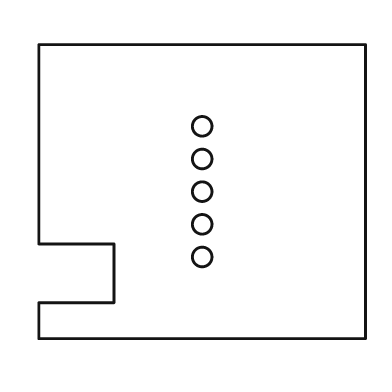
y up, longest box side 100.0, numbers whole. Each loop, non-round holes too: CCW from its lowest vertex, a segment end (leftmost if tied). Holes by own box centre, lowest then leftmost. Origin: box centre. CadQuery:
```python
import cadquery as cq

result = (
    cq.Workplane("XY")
    .moveTo(-50.0, -45.0)
    .lineTo(50.0, -45.0)
    .lineTo(50.0, 45.0)
    .lineTo(-50.0, 45.0)
    .lineTo(-50.0, -16.0)
    .lineTo(-27.0, -16.0)
    .lineTo(-27.0, -34.0)
    .lineTo(-50.0, -34.0)
    .close()
    .moveTo(0.0, -20.0)
    .circle(3.0)
    .moveTo(0.0, -10.0)
    .circle(3.0)
    .moveTo(0.0, 0.0)
    .circle(3.0)
    .moveTo(0.0, 10.0)
    .circle(3.0)
    .moveTo(0.0, 20.0)
    .circle(3.0)
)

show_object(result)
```